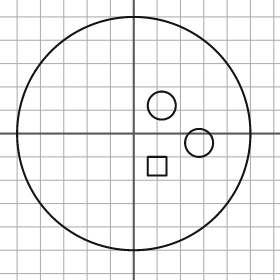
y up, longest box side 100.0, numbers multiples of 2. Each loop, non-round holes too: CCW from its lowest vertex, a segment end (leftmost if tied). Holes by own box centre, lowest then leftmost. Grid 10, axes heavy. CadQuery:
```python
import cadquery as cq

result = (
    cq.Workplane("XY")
    .moveTo(0.0, 0.0)
    .circle(50.0)
    .moveTo(6.0, -18.0)
    .lineTo(14.0, -18.0)
    .lineTo(14.0, -10.0)
    .lineTo(6.0, -10.0)
    .close()
    .moveTo(28.0, -4.0)
    .circle(6.0)
    .moveTo(12.0, 12.0)
    .circle(6.0)
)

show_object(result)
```